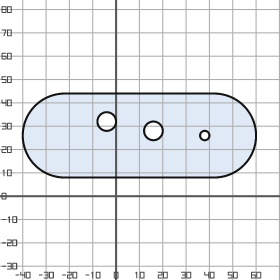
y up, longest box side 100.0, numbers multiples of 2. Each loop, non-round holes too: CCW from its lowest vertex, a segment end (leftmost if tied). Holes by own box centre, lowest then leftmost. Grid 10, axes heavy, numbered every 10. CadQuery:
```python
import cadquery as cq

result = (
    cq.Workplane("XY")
    .moveTo(-22.0, 8.0)
    .lineTo(42.0, 8.0)
    .threePointArc((60.0, 26.0), (42.0, 44.0))
    .lineTo(-22.0, 44.0)
    .threePointArc((-40.0, 26.0), (-22.0, 8.0))
    .close()
    .moveTo(38.0, 26.0)
    .circle(2.0)
    .moveTo(16.0, 28.0)
    .circle(4.0)
    .moveTo(-4.0, 32.0)
    .circle(4.0)
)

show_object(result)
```